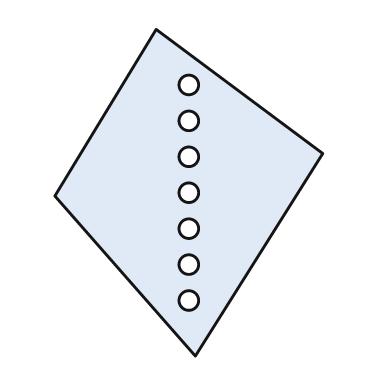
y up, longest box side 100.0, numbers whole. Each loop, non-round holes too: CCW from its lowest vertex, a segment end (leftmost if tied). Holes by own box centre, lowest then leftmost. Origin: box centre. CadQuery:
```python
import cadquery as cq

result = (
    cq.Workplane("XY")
    .moveTo(2.0, -50.0)
    .lineTo(41.0, 12.0)
    .lineTo(-10.0, 50.0)
    .lineTo(-41.0, -1.0)
    .close()
    .moveTo(0.0, -33.0)
    .circle(3.0)
    .moveTo(0.0, -22.0)
    .circle(3.0)
    .moveTo(0.0, -11.0)
    .circle(3.0)
    .moveTo(0.0, 0.0)
    .circle(3.0)
    .moveTo(0.0, 11.0)
    .circle(3.0)
    .moveTo(0.0, 22.0)
    .circle(3.0)
    .moveTo(0.0, 33.0)
    .circle(3.0)
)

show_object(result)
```